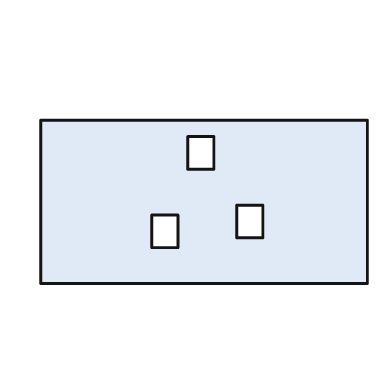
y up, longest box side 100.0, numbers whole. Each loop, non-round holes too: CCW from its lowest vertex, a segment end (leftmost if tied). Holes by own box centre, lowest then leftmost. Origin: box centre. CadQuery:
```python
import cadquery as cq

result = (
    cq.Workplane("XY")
    .moveTo(-50.0, -25.0)
    .lineTo(50.0, -25.0)
    .lineTo(50.0, 25.0)
    .lineTo(-50.0, 25.0)
    .close()
    .moveTo(-16.0, -14.0)
    .lineTo(-8.0, -14.0)
    .lineTo(-8.0, -4.0)
    .lineTo(-16.0, -4.0)
    .close()
    .moveTo(10.0, -11.0)
    .lineTo(18.0, -11.0)
    .lineTo(18.0, -1.0)
    .lineTo(10.0, -1.0)
    .close()
    .moveTo(-5.0, 10.0)
    .lineTo(3.0, 10.0)
    .lineTo(3.0, 20.0)
    .lineTo(-5.0, 20.0)
    .close()
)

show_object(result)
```